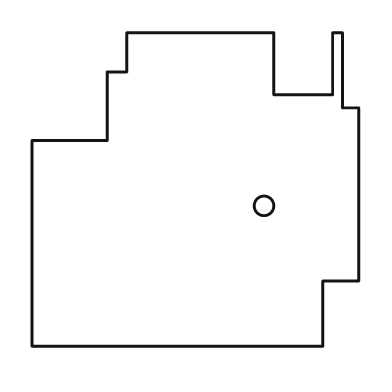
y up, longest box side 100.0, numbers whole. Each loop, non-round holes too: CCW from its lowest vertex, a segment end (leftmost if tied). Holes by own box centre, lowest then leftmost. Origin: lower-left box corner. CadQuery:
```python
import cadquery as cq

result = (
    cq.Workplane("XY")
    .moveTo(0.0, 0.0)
    .lineTo(89.0, 0.0)
    .lineTo(89.0, 20.0)
    .lineTo(100.0, 20.0)
    .lineTo(100.0, 73.0)
    .lineTo(95.0, 73.0)
    .lineTo(95.0, 96.0)
    .lineTo(92.0, 96.0)
    .lineTo(92.0, 77.0)
    .lineTo(74.0, 77.0)
    .lineTo(74.0, 96.0)
    .lineTo(29.0, 96.0)
    .lineTo(29.0, 84.0)
    .lineTo(23.0, 84.0)
    .lineTo(23.0, 63.0)
    .lineTo(0.0, 63.0)
    .close()
    .moveTo(71.0, 43.0)
    .circle(3.0)
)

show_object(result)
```